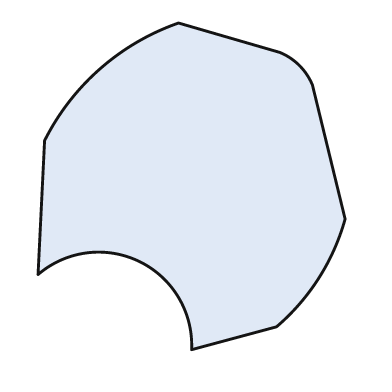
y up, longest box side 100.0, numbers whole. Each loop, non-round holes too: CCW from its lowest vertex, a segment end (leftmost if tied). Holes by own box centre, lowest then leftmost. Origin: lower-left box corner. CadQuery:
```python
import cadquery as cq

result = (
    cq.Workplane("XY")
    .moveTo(47.0, 0.0)
    .lineTo(73.0, 7.0)
    .threePointArc((86.0, 22.0), (94.0, 40.0))
    .lineTo(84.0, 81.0)
    .threePointArc((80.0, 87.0), (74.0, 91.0))
    .lineTo(43.0, 100.0)
    .threePointArc((19.0, 86.0), (2.0, 64.0))
    .lineTo(0.0, 23.0)
    .threePointArc((31.0, 27.0), (47.0, 0.0))
    .close()
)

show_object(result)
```